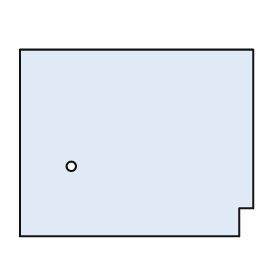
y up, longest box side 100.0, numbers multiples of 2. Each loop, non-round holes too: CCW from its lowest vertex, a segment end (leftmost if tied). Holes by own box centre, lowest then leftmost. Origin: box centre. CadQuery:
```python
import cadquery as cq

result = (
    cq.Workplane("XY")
    .moveTo(-50.0, -40.0)
    .lineTo(44.0, -40.0)
    .lineTo(44.0, -28.0)
    .lineTo(50.0, -28.0)
    .lineTo(50.0, 40.0)
    .lineTo(-50.0, 40.0)
    .close()
    .moveTo(-28.0, -10.0)
    .circle(2.0)
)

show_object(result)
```